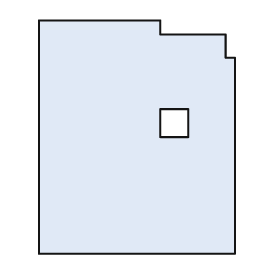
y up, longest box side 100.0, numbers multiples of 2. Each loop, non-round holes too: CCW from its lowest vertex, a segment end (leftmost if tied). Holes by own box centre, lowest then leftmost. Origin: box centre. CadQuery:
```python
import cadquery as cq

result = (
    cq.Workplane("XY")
    .moveTo(-42.0, -50.0)
    .lineTo(42.0, -50.0)
    .lineTo(42.0, 34.0)
    .lineTo(38.0, 34.0)
    .lineTo(38.0, 44.0)
    .lineTo(10.0, 44.0)
    .lineTo(10.0, 50.0)
    .lineTo(-42.0, 50.0)
    .close()
    .moveTo(10.0, 0.0)
    .lineTo(22.0, 0.0)
    .lineTo(22.0, 12.0)
    .lineTo(10.0, 12.0)
    .close()
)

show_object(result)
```